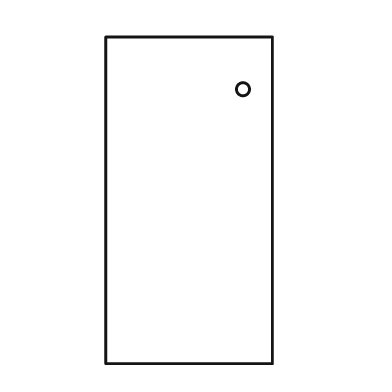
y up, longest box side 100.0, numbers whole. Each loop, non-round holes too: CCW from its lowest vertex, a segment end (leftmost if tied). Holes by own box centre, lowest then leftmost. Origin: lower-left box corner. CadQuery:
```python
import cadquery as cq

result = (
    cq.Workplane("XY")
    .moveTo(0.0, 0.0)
    .lineTo(51.0, 0.0)
    .lineTo(51.0, 100.0)
    .lineTo(0.0, 100.0)
    .close()
    .moveTo(42.0, 84.0)
    .circle(2.0)
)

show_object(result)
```